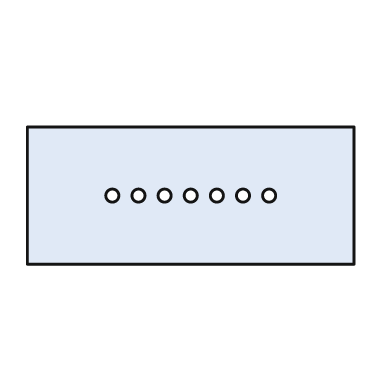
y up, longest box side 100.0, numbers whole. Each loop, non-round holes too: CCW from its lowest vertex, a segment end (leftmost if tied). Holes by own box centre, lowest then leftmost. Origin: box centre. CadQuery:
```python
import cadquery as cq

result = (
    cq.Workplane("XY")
    .moveTo(-50.0, -21.0)
    .lineTo(50.0, -21.0)
    .lineTo(50.0, 21.0)
    .lineTo(-50.0, 21.0)
    .close()
    .moveTo(-24.0, 0.0)
    .circle(2.0)
    .moveTo(-16.0, 0.0)
    .circle(2.0)
    .moveTo(-8.0, 0.0)
    .circle(2.0)
    .moveTo(0.0, 0.0)
    .circle(2.0)
    .moveTo(8.0, 0.0)
    .circle(2.0)
    .moveTo(16.0, 0.0)
    .circle(2.0)
    .moveTo(24.0, 0.0)
    .circle(2.0)
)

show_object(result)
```